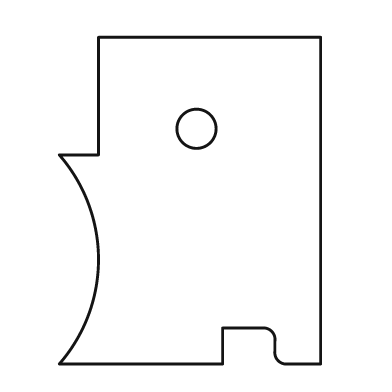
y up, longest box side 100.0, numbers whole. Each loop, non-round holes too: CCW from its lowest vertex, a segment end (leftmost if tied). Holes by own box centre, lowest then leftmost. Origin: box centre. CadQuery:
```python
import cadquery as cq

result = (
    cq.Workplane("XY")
    .moveTo(-40.0, -50.0)
    .lineTo(10.0, -50.0)
    .lineTo(10.0, -39.0)
    .lineTo(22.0, -39.0)
    .threePointArc((25.0, -40.0), (26.0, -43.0))
    .lineTo(26.0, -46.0)
    .threePointArc((27.0, -49.0), (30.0, -50.0))
    .lineTo(40.0, -50.0)
    .lineTo(40.0, 50.0)
    .lineTo(-28.0, 50.0)
    .lineTo(-28.0, 14.0)
    .lineTo(-40.0, 14.0)
    .threePointArc((-28.0, -18.0), (-40.0, -50.0))
    .close()
    .moveTo(2.0, 22.0)
    .circle(6.0)
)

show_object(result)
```